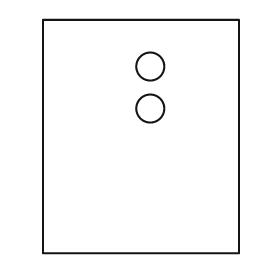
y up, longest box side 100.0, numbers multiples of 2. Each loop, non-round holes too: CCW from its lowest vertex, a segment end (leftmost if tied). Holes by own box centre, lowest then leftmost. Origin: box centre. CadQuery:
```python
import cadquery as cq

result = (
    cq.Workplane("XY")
    .moveTo(-42.0, -50.0)
    .lineTo(42.0, -50.0)
    .lineTo(42.0, 50.0)
    .lineTo(-42.0, 50.0)
    .close()
    .moveTo(4.0, 12.0)
    .circle(6.0)
    .moveTo(4.0, 30.0)
    .circle(6.0)
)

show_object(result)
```